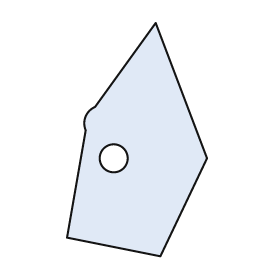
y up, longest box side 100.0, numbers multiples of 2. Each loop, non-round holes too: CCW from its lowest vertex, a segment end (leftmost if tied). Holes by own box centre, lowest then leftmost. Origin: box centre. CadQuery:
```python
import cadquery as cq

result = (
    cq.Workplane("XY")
    .moveTo(10.0, -50.0)
    .lineTo(30.0, -8.0)
    .lineTo(8.0, 50.0)
    .lineTo(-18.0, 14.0)
    .threePointArc((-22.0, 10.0), (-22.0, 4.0))
    .lineTo(-30.0, -42.0)
    .close()
    .moveTo(-10.0, -8.0)
    .circle(6.0)
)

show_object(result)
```